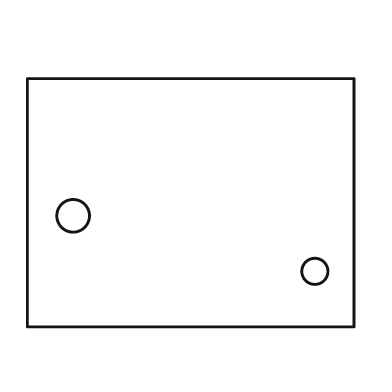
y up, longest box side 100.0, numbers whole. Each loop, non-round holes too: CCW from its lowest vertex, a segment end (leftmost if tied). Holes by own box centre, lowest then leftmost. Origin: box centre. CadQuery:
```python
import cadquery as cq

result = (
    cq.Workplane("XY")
    .moveTo(-50.0, -38.0)
    .lineTo(50.0, -38.0)
    .lineTo(50.0, 38.0)
    .lineTo(-50.0, 38.0)
    .close()
    .moveTo(38.0, -21.0)
    .circle(4.0)
    .moveTo(-36.0, -4.0)
    .circle(5.0)
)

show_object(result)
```